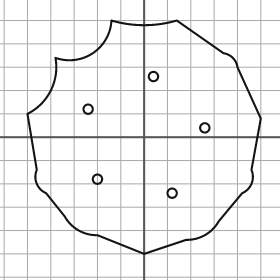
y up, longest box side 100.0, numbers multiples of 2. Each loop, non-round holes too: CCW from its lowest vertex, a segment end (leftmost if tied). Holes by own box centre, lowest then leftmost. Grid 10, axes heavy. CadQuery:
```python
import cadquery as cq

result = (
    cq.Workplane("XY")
    .moveTo(0.0, -50.0)
    .lineTo(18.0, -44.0)
    .threePointArc((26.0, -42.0), (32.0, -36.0))
    .lineTo(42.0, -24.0)
    .threePointArc((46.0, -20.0), (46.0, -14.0))
    .lineTo(50.0, 8.0)
    .lineTo(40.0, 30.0)
    .threePointArc((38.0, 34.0), (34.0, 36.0))
    .lineTo(14.0, 50.0)
    .threePointArc((0.0, 48.0), (-14.0, 50.0))
    .threePointArc((-22.0, 36.0), (-38.0, 34.0))
    .threePointArc((-40.0, 20.0), (-50.0, 10.0))
    .lineTo(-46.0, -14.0)
    .threePointArc((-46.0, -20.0), (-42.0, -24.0))
    .lineTo(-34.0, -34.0)
    .threePointArc((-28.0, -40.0), (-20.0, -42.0))
    .close()
    .moveTo(12.0, -24.0)
    .circle(2.0)
    .moveTo(-20.0, -18.0)
    .circle(2.0)
    .moveTo(26.0, 4.0)
    .circle(2.0)
    .moveTo(-24.0, 12.0)
    .circle(2.0)
    .moveTo(4.0, 26.0)
    .circle(2.0)
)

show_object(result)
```